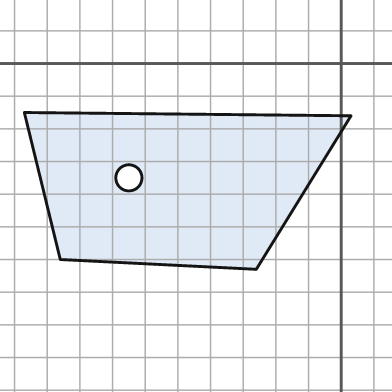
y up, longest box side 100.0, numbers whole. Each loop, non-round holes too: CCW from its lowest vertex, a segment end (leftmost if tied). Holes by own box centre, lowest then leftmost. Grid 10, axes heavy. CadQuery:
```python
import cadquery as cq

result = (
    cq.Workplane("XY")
    .moveTo(-26.0, -63.0)
    .lineTo(3.0, -16.0)
    .lineTo(-97.0, -15.0)
    .lineTo(-86.0, -60.0)
    .close()
    .moveTo(-65.0, -35.0)
    .circle(4.0)
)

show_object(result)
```